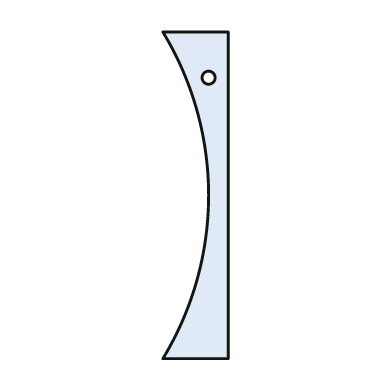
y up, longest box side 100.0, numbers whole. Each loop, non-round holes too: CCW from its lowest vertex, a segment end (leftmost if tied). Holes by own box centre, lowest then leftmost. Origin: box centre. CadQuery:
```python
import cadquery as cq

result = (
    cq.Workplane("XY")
    .moveTo(-10.0, -50.0)
    .lineTo(10.0, -50.0)
    .lineTo(10.0, 50.0)
    .lineTo(-10.0, 50.0)
    .threePointArc((4.0, 0.0), (-10.0, -50.0))
    .close()
    .moveTo(4.0, 36.0)
    .circle(2.0)
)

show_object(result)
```